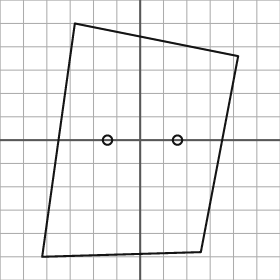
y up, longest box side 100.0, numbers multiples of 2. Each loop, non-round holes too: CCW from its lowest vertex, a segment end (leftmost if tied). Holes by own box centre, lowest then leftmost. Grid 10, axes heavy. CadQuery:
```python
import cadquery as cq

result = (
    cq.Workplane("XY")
    .moveTo(-42.0, -50.0)
    .lineTo(26.0, -48.0)
    .lineTo(42.0, 36.0)
    .lineTo(-28.0, 50.0)
    .close()
    .moveTo(-14.0, 0.0)
    .circle(2.0)
    .moveTo(16.0, 0.0)
    .circle(2.0)
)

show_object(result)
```